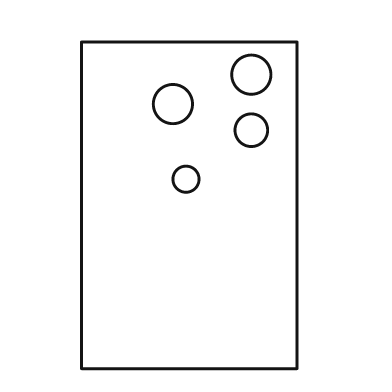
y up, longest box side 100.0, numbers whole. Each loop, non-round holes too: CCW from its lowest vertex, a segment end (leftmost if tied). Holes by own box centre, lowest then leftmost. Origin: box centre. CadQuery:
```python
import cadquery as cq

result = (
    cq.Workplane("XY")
    .moveTo(-33.0, -50.0)
    .lineTo(33.0, -50.0)
    .lineTo(33.0, 50.0)
    .lineTo(-33.0, 50.0)
    .close()
    .moveTo(-1.0, 8.0)
    .circle(4.0)
    .moveTo(19.0, 23.0)
    .circle(5.0)
    .moveTo(-5.0, 31.0)
    .circle(6.0)
    .moveTo(19.0, 40.0)
    .circle(6.0)
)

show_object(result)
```